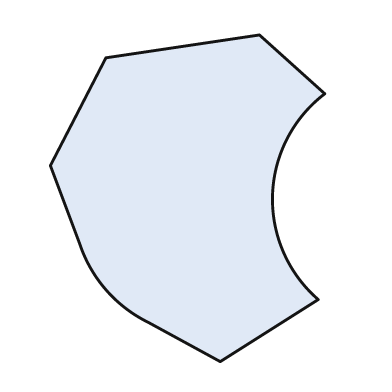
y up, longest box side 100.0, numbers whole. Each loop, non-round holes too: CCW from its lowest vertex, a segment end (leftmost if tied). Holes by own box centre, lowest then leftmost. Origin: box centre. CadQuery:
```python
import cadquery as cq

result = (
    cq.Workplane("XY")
    .moveTo(10.0, -50.0)
    .lineTo(40.0, -31.0)
    .threePointArc((26.0, 1.0), (42.0, 32.0))
    .lineTo(22.0, 50.0)
    .lineTo(-25.0, 43.0)
    .lineTo(-42.0, 10.0)
    .lineTo(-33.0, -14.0)
    .threePointArc((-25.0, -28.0), (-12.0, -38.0))
    .close()
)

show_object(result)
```